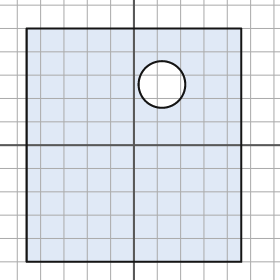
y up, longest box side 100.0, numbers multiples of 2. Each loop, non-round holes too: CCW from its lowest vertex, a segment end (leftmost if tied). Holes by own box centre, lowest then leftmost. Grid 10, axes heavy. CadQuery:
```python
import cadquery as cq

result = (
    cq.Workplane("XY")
    .moveTo(-46.0, -50.0)
    .lineTo(46.0, -50.0)
    .lineTo(46.0, 50.0)
    .lineTo(-46.0, 50.0)
    .close()
    .moveTo(12.0, 26.0)
    .circle(10.0)
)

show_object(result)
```